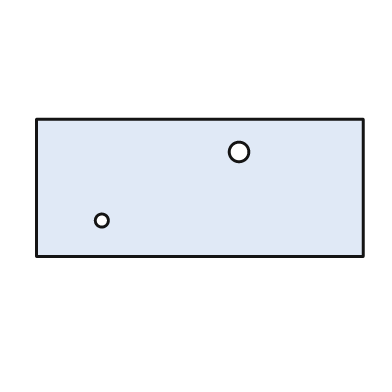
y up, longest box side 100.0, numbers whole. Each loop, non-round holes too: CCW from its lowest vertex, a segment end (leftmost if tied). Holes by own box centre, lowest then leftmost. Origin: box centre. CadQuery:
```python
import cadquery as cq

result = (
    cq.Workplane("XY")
    .moveTo(-50.0, -21.0)
    .lineTo(50.0, -21.0)
    .lineTo(50.0, 21.0)
    .lineTo(-50.0, 21.0)
    .close()
    .moveTo(-30.0, -10.0)
    .circle(2.0)
    .moveTo(12.0, 11.0)
    .circle(3.0)
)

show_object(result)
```